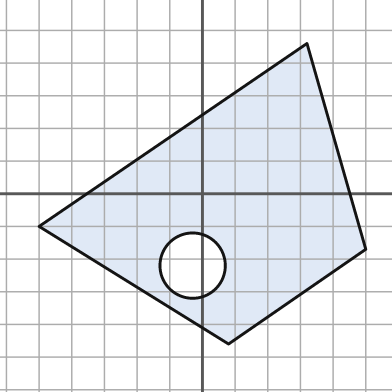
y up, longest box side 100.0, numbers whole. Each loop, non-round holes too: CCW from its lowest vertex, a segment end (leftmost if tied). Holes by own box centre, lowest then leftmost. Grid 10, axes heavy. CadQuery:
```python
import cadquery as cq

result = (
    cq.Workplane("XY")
    .moveTo(8.0, -46.0)
    .lineTo(50.0, -17.0)
    .lineTo(32.0, 46.0)
    .lineTo(-50.0, -10.0)
    .close()
    .moveTo(-3.0, -22.0)
    .circle(10.0)
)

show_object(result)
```